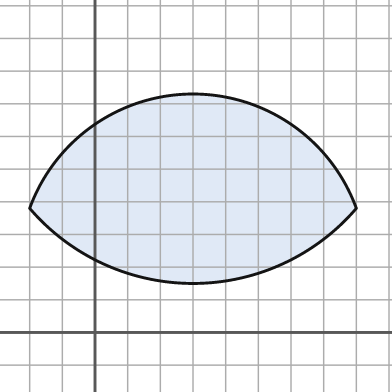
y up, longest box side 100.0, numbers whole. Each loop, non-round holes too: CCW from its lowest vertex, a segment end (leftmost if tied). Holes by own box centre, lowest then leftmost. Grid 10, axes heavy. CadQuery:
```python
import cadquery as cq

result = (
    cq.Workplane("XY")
    .moveTo(-20.0, 38.0)
    .threePointArc((30.0, 15.0), (80.0, 38.0))
    .threePointArc((30.0, 73.0), (-20.0, 38.0))
    .close()
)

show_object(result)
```